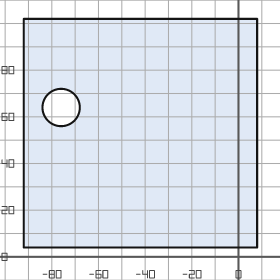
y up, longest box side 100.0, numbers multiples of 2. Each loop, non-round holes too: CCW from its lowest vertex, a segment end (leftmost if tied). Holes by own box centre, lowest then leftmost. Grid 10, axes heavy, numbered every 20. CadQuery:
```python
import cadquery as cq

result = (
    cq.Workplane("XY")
    .moveTo(-92.0, 4.0)
    .lineTo(8.0, 4.0)
    .lineTo(8.0, 102.0)
    .lineTo(-92.0, 102.0)
    .close()
    .moveTo(-76.0, 64.0)
    .circle(8.0)
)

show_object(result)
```